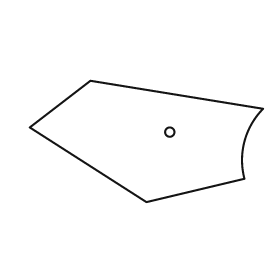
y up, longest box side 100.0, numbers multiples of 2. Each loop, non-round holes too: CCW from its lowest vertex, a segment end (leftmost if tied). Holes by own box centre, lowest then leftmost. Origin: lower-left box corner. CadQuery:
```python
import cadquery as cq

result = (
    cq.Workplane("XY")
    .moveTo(50.0, 0.0)
    .lineTo(92.0, 10.0)
    .threePointArc((92.0, 26.0), (100.0, 40.0))
    .lineTo(26.0, 52.0)
    .lineTo(0.0, 32.0)
    .close()
    .moveTo(60.0, 30.0)
    .circle(2.0)
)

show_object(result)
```